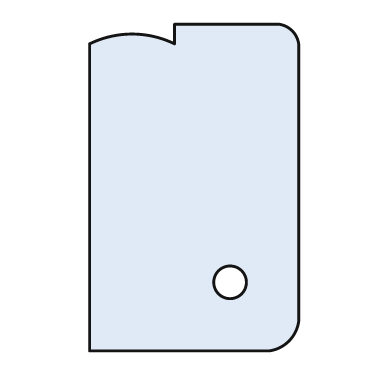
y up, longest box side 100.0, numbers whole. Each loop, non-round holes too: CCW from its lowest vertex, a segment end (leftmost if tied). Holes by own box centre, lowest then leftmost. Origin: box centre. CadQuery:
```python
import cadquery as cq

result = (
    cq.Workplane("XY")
    .moveTo(-32.0, -50.0)
    .lineTo(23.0, -50.0)
    .threePointArc((29.0, -47.0), (32.0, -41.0))
    .lineTo(32.0, 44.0)
    .threePointArc((30.0, 48.0), (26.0, 50.0))
    .lineTo(-6.0, 50.0)
    .lineTo(-6.0, 44.0)
    .threePointArc((-19.0, 47.0), (-32.0, 44.0))
    .close()
    .moveTo(11.0, -29.0)
    .circle(5.0)
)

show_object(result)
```